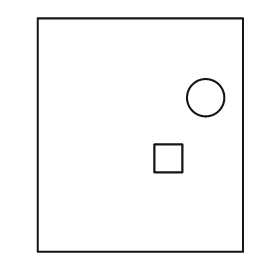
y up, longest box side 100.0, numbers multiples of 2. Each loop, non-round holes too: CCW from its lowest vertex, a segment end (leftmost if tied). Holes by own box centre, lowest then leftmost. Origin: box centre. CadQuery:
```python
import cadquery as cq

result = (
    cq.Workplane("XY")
    .moveTo(-44.0, -50.0)
    .lineTo(44.0, -50.0)
    .lineTo(44.0, 50.0)
    .lineTo(-44.0, 50.0)
    .close()
    .moveTo(6.0, -16.0)
    .lineTo(18.0, -16.0)
    .lineTo(18.0, -4.0)
    .lineTo(6.0, -4.0)
    .close()
    .moveTo(28.0, 16.0)
    .circle(8.0)
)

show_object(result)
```